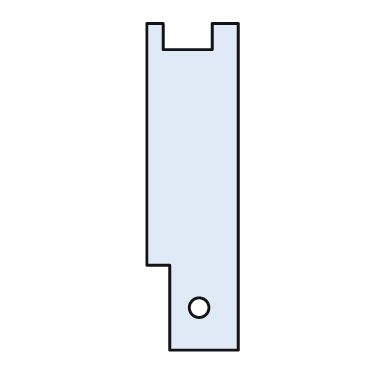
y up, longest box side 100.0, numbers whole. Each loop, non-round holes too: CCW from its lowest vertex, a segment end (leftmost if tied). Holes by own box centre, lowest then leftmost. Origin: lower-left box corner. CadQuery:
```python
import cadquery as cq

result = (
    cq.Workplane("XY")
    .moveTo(7.0, 0.0)
    .lineTo(28.0, 0.0)
    .lineTo(28.0, 100.0)
    .lineTo(20.0, 100.0)
    .lineTo(20.0, 92.0)
    .lineTo(5.0, 92.0)
    .lineTo(5.0, 100.0)
    .lineTo(0.0, 100.0)
    .lineTo(0.0, 26.0)
    .lineTo(7.0, 26.0)
    .close()
    .moveTo(16.0, 13.0)
    .circle(3.0)
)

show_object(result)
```